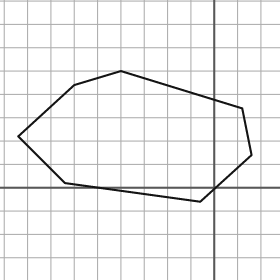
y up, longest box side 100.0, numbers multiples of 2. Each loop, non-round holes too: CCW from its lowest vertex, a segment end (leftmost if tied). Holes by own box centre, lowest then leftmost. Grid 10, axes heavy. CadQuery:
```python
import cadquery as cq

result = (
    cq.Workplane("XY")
    .moveTo(-6.0, -6.0)
    .lineTo(16.0, 14.0)
    .lineTo(12.0, 34.0)
    .lineTo(-40.0, 50.0)
    .lineTo(-60.0, 44.0)
    .lineTo(-84.0, 22.0)
    .lineTo(-64.0, 2.0)
    .close()
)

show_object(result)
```